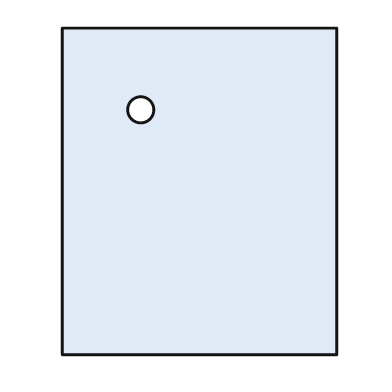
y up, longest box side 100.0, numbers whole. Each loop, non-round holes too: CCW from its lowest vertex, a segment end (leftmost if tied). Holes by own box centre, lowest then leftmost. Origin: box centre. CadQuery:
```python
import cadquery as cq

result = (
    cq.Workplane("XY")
    .moveTo(-42.0, -50.0)
    .lineTo(42.0, -50.0)
    .lineTo(42.0, 50.0)
    .lineTo(-42.0, 50.0)
    .close()
    .moveTo(-18.0, 25.0)
    .circle(4.0)
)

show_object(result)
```